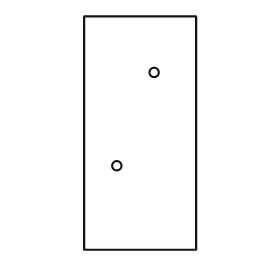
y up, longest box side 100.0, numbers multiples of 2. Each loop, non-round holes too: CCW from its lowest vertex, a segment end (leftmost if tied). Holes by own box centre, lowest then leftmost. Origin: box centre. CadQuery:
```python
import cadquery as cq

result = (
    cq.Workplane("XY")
    .moveTo(-24.0, -50.0)
    .lineTo(24.0, -50.0)
    .lineTo(24.0, 50.0)
    .lineTo(-24.0, 50.0)
    .close()
    .moveTo(-10.0, -14.0)
    .circle(2.0)
    .moveTo(6.0, 26.0)
    .circle(2.0)
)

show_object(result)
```